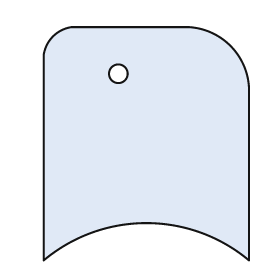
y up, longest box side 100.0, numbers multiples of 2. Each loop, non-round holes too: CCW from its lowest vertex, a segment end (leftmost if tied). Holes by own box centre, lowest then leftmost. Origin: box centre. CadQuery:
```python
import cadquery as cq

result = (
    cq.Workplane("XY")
    .moveTo(-44.0, -50.0)
    .threePointArc((0.0, -34.0), (44.0, -50.0))
    .lineTo(44.0, 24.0)
    .threePointArc((36.0, 42.0), (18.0, 50.0))
    .lineTo(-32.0, 50.0)
    .threePointArc((-40.0, 46.0), (-44.0, 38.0))
    .close()
    .moveTo(-12.0, 30.0)
    .circle(4.0)
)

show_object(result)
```